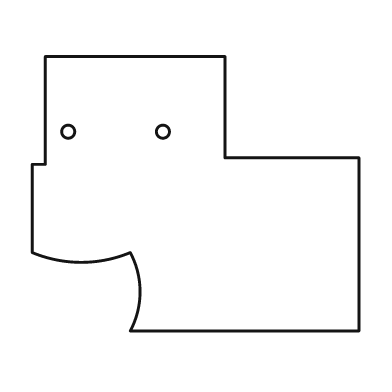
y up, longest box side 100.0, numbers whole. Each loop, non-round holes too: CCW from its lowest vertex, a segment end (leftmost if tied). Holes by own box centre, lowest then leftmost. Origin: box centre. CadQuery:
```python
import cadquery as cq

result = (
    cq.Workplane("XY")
    .moveTo(-20.0, -42.0)
    .lineTo(50.0, -42.0)
    .lineTo(50.0, 11.0)
    .lineTo(9.0, 11.0)
    .lineTo(9.0, 42.0)
    .lineTo(-46.0, 42.0)
    .lineTo(-46.0, 9.0)
    .lineTo(-50.0, 9.0)
    .lineTo(-50.0, -18.0)
    .threePointArc((-35.0, -21.0), (-20.0, -18.0))
    .threePointArc((-17.0, -30.0), (-20.0, -42.0))
    .close()
    .moveTo(-39.0, 19.0)
    .circle(2.0)
    .moveTo(-10.0, 19.0)
    .circle(2.0)
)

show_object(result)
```